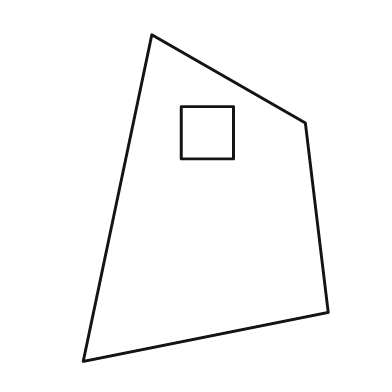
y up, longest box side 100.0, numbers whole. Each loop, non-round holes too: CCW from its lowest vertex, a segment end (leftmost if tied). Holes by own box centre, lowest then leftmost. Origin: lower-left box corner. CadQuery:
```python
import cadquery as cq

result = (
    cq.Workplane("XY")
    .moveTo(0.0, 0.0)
    .lineTo(75.0, 15.0)
    .lineTo(68.0, 73.0)
    .lineTo(21.0, 100.0)
    .close()
    .moveTo(30.0, 62.0)
    .lineTo(46.0, 62.0)
    .lineTo(46.0, 78.0)
    .lineTo(30.0, 78.0)
    .close()
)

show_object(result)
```